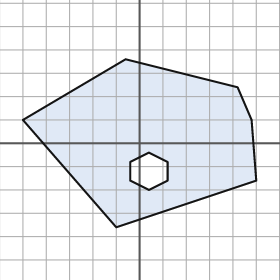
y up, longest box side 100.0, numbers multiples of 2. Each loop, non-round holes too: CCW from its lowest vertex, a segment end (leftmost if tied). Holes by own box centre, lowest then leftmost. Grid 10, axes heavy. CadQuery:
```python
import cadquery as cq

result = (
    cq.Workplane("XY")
    .moveTo(-10.0, -36.0)
    .lineTo(50.0, -16.0)
    .lineTo(48.0, 10.0)
    .lineTo(42.0, 24.0)
    .lineTo(-6.0, 36.0)
    .lineTo(-50.0, 10.0)
    .close()
    .moveTo(4.0, -20.0)
    .lineTo(12.0, -16.0)
    .lineTo(12.0, -8.0)
    .lineTo(4.0, -4.0)
    .lineTo(-4.0, -8.0)
    .lineTo(-4.0, -16.0)
    .close()
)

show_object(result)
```